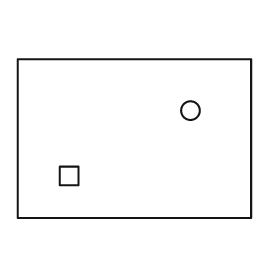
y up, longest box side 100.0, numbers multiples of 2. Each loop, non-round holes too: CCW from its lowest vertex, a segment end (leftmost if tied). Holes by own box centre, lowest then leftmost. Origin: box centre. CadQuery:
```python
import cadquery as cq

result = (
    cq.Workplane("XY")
    .moveTo(-50.0, -34.0)
    .lineTo(50.0, -34.0)
    .lineTo(50.0, 34.0)
    .lineTo(-50.0, 34.0)
    .close()
    .moveTo(-32.0, -20.0)
    .lineTo(-24.0, -20.0)
    .lineTo(-24.0, -12.0)
    .lineTo(-32.0, -12.0)
    .close()
    .moveTo(24.0, 12.0)
    .circle(4.0)
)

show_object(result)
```